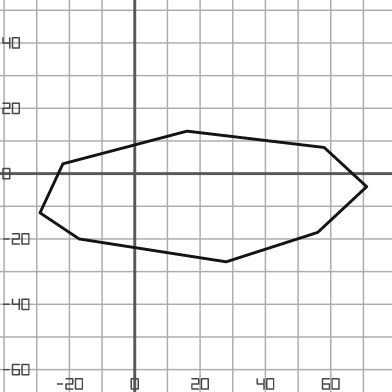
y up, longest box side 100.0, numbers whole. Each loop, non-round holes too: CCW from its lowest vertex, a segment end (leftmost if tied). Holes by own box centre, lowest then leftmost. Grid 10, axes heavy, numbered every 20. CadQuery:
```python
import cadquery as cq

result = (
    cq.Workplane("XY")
    .moveTo(28.0, -27.0)
    .lineTo(56.0, -18.0)
    .lineTo(71.0, -4.0)
    .lineTo(58.0, 8.0)
    .lineTo(16.0, 13.0)
    .lineTo(-22.0, 3.0)
    .lineTo(-29.0, -12.0)
    .lineTo(-17.0, -20.0)
    .close()
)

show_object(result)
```